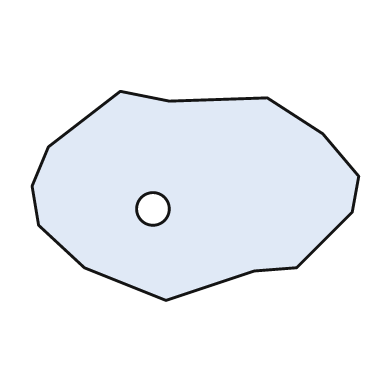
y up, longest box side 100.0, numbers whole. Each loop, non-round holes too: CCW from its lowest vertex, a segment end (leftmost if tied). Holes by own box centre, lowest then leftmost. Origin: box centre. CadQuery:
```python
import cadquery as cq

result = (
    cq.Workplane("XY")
    .moveTo(-9.0, -32.0)
    .lineTo(18.0, -23.0)
    .lineTo(31.0, -22.0)
    .lineTo(48.0, -5.0)
    .lineTo(50.0, 6.0)
    .lineTo(39.0, 19.0)
    .lineTo(22.0, 30.0)
    .lineTo(-8.0, 29.0)
    .lineTo(-23.0, 32.0)
    .lineTo(-45.0, 15.0)
    .lineTo(-50.0, 3.0)
    .lineTo(-48.0, -9.0)
    .lineTo(-34.0, -22.0)
    .close()
    .moveTo(-13.0, -4.0)
    .circle(5.0)
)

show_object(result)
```